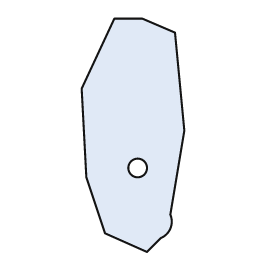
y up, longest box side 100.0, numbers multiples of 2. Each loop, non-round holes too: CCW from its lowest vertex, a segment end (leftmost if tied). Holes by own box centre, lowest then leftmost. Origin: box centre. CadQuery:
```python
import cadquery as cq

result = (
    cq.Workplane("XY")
    .moveTo(6.0, -50.0)
    .lineTo(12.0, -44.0)
    .threePointArc((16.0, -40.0), (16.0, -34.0))
    .lineTo(22.0, 2.0)
    .lineTo(18.0, 44.0)
    .lineTo(4.0, 50.0)
    .lineTo(-8.0, 50.0)
    .lineTo(-22.0, 20.0)
    .lineTo(-20.0, -18.0)
    .lineTo(-12.0, -42.0)
    .close()
    .moveTo(2.0, -14.0)
    .circle(4.0)
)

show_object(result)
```